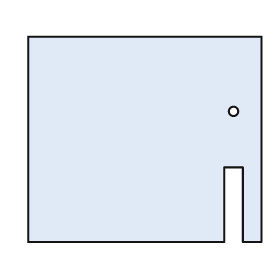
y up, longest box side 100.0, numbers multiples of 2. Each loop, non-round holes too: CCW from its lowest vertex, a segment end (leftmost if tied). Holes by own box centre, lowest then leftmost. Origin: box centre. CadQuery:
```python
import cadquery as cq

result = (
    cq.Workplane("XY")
    .moveTo(-50.0, -44.0)
    .lineTo(34.0, -44.0)
    .lineTo(34.0, -12.0)
    .lineTo(42.0, -12.0)
    .lineTo(42.0, -44.0)
    .lineTo(50.0, -44.0)
    .lineTo(50.0, 44.0)
    .lineTo(-50.0, 44.0)
    .close()
    .moveTo(38.0, 12.0)
    .circle(2.0)
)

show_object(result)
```